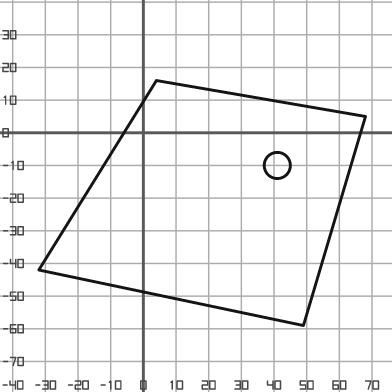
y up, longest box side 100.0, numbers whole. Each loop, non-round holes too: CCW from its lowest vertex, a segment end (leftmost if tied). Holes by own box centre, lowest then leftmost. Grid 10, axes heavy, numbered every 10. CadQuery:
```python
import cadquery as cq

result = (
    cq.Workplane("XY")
    .moveTo(49.0, -59.0)
    .lineTo(68.0, 5.0)
    .lineTo(4.0, 16.0)
    .lineTo(-32.0, -42.0)
    .close()
    .moveTo(41.0, -10.0)
    .circle(4.0)
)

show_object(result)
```